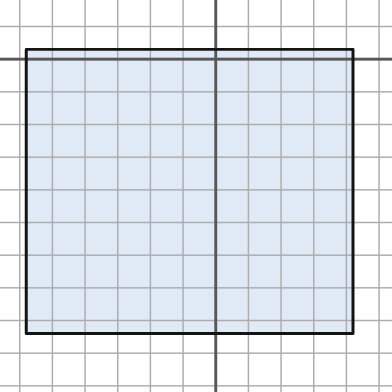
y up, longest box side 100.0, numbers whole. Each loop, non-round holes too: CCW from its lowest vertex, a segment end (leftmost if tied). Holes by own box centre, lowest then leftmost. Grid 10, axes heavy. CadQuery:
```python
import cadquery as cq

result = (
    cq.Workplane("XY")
    .moveTo(-58.0, -84.0)
    .lineTo(42.0, -84.0)
    .lineTo(42.0, 3.0)
    .lineTo(-58.0, 3.0)
    .close()
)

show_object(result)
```